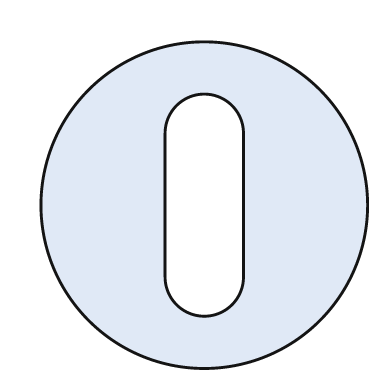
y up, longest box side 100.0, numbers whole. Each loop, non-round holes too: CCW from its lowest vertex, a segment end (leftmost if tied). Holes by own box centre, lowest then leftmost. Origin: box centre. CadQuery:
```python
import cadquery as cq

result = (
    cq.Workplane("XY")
    .moveTo(0.0, 0.0)
    .circle(50.0)
    .moveTo(-12.0, -22.0)
    .threePointArc((0.0, -34.0), (12.0, -22.0))
    .lineTo(12.0, 22.0)
    .threePointArc((0.0, 34.0), (-12.0, 22.0))
    .close()
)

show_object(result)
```